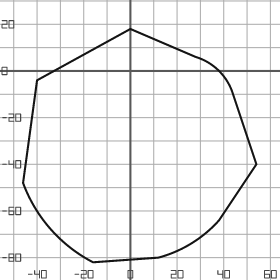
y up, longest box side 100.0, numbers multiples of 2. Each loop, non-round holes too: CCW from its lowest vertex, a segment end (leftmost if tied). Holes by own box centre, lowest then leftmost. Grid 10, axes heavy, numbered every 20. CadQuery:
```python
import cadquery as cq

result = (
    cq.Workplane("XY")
    .moveTo(-16.0, -82.0)
    .lineTo(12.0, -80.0)
    .threePointArc((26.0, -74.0), (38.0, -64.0))
    .lineTo(54.0, -40.0)
    .lineTo(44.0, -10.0)
    .threePointArc((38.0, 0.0), (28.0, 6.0))
    .lineTo(0.0, 18.0)
    .lineTo(-40.0, -4.0)
    .lineTo(-46.0, -48.0)
    .threePointArc((-34.0, -68.0), (-16.0, -82.0))
    .close()
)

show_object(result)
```